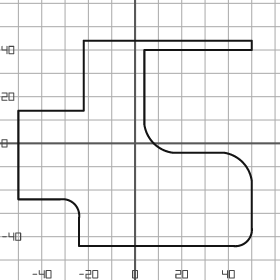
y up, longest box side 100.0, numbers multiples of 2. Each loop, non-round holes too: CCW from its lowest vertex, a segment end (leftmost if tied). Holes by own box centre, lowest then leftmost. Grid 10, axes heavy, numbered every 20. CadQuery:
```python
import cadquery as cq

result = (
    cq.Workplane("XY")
    .moveTo(-24.0, -44.0)
    .lineTo(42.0, -44.0)
    .threePointArc((48.0, -42.0), (50.0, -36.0))
    .lineTo(50.0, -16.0)
    .threePointArc((46.0, -8.0), (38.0, -4.0))
    .lineTo(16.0, -4.0)
    .threePointArc((8.0, 0.0), (4.0, 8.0))
    .lineTo(4.0, 40.0)
    .lineTo(50.0, 40.0)
    .lineTo(50.0, 44.0)
    .lineTo(-22.0, 44.0)
    .lineTo(-22.0, 14.0)
    .lineTo(-50.0, 14.0)
    .lineTo(-50.0, -24.0)
    .lineTo(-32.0, -24.0)
    .threePointArc((-26.0, -26.0), (-24.0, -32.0))
    .close()
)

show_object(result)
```